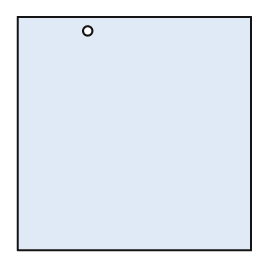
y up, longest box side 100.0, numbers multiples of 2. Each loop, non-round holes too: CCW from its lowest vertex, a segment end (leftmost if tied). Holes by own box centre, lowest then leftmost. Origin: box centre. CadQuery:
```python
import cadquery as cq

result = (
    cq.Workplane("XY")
    .moveTo(-50.0, -50.0)
    .lineTo(50.0, -50.0)
    .lineTo(50.0, 50.0)
    .lineTo(-50.0, 50.0)
    .close()
    .moveTo(-20.0, 44.0)
    .circle(2.0)
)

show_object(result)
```